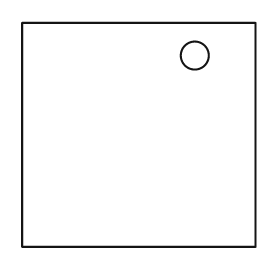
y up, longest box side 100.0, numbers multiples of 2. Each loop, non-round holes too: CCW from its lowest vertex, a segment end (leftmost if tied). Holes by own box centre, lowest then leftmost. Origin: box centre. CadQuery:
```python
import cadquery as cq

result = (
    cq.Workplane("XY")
    .moveTo(-50.0, -48.0)
    .lineTo(50.0, -48.0)
    .lineTo(50.0, 48.0)
    .lineTo(-50.0, 48.0)
    .close()
    .moveTo(24.0, 34.0)
    .circle(6.0)
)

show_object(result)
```